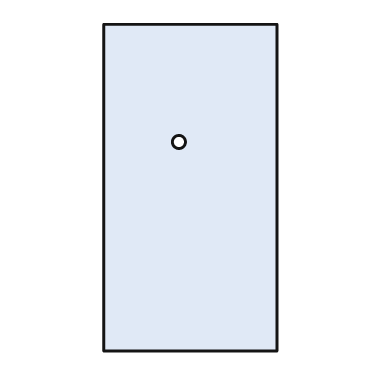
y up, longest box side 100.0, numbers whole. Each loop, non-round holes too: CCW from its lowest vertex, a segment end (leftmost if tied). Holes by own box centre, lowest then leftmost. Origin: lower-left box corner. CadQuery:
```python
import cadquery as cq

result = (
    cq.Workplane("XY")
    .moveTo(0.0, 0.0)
    .lineTo(53.0, 0.0)
    .lineTo(53.0, 100.0)
    .lineTo(0.0, 100.0)
    .close()
    .moveTo(23.0, 64.0)
    .circle(2.0)
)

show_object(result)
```